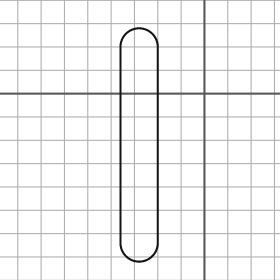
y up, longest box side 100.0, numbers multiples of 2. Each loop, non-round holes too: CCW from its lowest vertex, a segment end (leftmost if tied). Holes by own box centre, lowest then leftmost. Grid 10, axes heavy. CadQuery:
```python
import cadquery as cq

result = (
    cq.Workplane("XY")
    .moveTo(-36.0, -64.0)
    .threePointArc((-28.0, -72.0), (-20.0, -64.0))
    .lineTo(-20.0, 20.0)
    .threePointArc((-28.0, 28.0), (-36.0, 20.0))
    .close()
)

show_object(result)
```